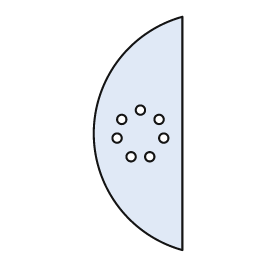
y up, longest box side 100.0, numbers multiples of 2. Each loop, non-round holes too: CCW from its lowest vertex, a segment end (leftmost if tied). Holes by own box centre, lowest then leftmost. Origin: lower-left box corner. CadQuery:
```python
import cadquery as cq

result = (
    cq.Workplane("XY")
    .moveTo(38.0, 0.0)
    .lineTo(38.0, 100.0)
    .threePointArc((0.0, 50.0), (38.0, 0.0))
    .close()
    .moveTo(16.0, 40.0)
    .circle(2.0)
    .moveTo(24.0, 40.0)
    .circle(2.0)
    .moveTo(10.0, 48.0)
    .circle(2.0)
    .moveTo(30.0, 48.0)
    .circle(2.0)
    .moveTo(12.0, 56.0)
    .circle(2.0)
    .moveTo(28.0, 56.0)
    .circle(2.0)
    .moveTo(20.0, 60.0)
    .circle(2.0)
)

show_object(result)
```